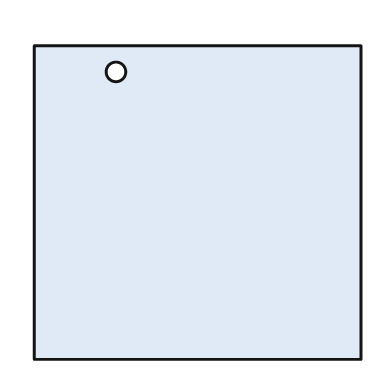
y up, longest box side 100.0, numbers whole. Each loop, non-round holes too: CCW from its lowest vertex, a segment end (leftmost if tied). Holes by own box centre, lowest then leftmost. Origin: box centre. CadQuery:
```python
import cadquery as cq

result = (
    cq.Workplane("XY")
    .moveTo(-50.0, -48.0)
    .lineTo(50.0, -48.0)
    .lineTo(50.0, 48.0)
    .lineTo(-50.0, 48.0)
    .close()
    .moveTo(-25.0, 40.0)
    .circle(3.0)
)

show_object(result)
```